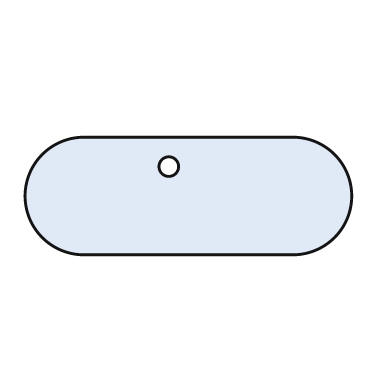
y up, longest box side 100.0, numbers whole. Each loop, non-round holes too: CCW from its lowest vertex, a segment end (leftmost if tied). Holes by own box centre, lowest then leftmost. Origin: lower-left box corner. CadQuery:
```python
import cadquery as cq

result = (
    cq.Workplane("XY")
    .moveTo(18.0, 0.0)
    .lineTo(82.0, 0.0)
    .threePointArc((100.0, 18.0), (82.0, 36.0))
    .lineTo(18.0, 36.0)
    .threePointArc((0.0, 18.0), (18.0, 0.0))
    .close()
    .moveTo(44.0, 27.0)
    .circle(3.0)
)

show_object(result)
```